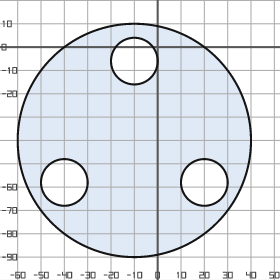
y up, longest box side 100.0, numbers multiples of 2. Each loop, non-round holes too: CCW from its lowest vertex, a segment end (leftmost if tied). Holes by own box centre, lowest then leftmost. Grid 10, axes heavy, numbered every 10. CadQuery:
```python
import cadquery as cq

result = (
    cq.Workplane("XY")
    .moveTo(-10.0, -40.0)
    .circle(50.0)
    .moveTo(-40.0, -58.0)
    .circle(10.0)
    .moveTo(20.0, -58.0)
    .circle(10.0)
    .moveTo(-10.0, -6.0)
    .circle(10.0)
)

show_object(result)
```